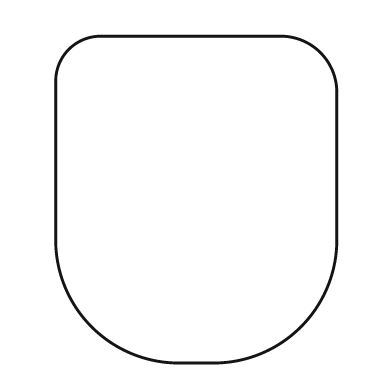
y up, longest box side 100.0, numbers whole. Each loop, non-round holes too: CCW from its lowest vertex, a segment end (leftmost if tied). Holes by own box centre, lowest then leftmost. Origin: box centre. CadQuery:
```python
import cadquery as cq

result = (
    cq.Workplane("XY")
    .moveTo(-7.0, -50.0)
    .lineTo(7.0, -50.0)
    .threePointArc((32.0, -39.0), (43.0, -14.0))
    .lineTo(43.0, 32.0)
    .threePointArc((38.0, 45.0), (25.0, 50.0))
    .lineTo(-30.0, 50.0)
    .threePointArc((-39.0, 46.0), (-43.0, 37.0))
    .lineTo(-43.0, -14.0)
    .threePointArc((-32.0, -39.0), (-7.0, -50.0))
    .close()
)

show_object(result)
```